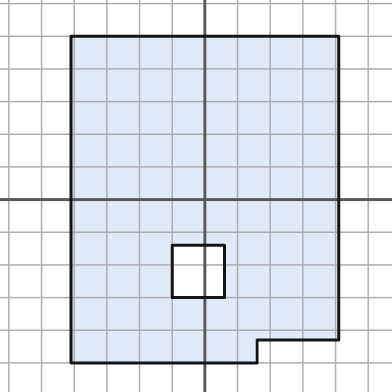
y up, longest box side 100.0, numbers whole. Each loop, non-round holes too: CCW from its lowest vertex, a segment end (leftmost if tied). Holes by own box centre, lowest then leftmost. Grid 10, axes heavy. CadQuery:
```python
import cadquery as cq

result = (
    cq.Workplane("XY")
    .moveTo(-41.0, -50.0)
    .lineTo(16.0, -50.0)
    .lineTo(16.0, -43.0)
    .lineTo(41.0, -43.0)
    .lineTo(41.0, 50.0)
    .lineTo(-41.0, 50.0)
    .close()
    .moveTo(-10.0, -30.0)
    .lineTo(6.0, -30.0)
    .lineTo(6.0, -14.0)
    .lineTo(-10.0, -14.0)
    .close()
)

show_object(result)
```